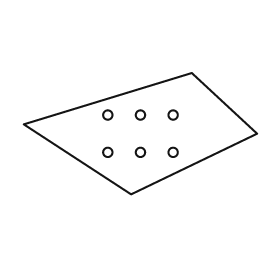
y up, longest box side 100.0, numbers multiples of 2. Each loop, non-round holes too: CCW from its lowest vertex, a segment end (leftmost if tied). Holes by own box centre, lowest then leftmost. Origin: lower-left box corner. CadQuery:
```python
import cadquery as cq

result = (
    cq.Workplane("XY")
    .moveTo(46.0, 0.0)
    .lineTo(100.0, 26.0)
    .lineTo(72.0, 52.0)
    .lineTo(0.0, 30.0)
    .close()
    .moveTo(36.0, 18.0)
    .circle(2.0)
    .moveTo(50.0, 18.0)
    .circle(2.0)
    .moveTo(64.0, 18.0)
    .circle(2.0)
    .moveTo(36.0, 34.0)
    .circle(2.0)
    .moveTo(50.0, 34.0)
    .circle(2.0)
    .moveTo(64.0, 34.0)
    .circle(2.0)
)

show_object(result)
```